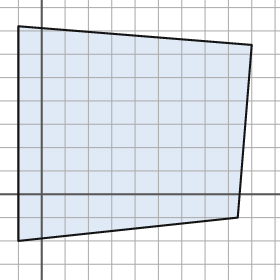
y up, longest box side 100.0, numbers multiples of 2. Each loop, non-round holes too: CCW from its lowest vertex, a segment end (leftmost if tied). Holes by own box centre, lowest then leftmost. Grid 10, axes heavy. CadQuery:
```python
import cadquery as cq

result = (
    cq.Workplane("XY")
    .moveTo(-10.0, -20.0)
    .lineTo(84.0, -10.0)
    .lineTo(90.0, 64.0)
    .lineTo(-10.0, 72.0)
    .close()
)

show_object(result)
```